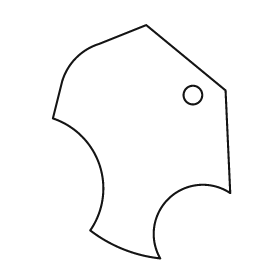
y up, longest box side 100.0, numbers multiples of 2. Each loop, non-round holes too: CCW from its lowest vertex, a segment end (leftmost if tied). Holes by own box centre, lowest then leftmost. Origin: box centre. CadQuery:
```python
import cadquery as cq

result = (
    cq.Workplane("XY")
    .moveTo(8.0, -50.0)
    .threePointArc((12.0, -24.0), (38.0, -22.0))
    .lineTo(36.0, 22.0)
    .lineTo(2.0, 50.0)
    .lineTo(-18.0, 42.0)
    .threePointArc((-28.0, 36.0), (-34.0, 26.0))
    .lineTo(-38.0, 10.0)
    .threePointArc((-18.0, -10.0), (-22.0, -38.0))
    .threePointArc((-8.0, -46.0), (8.0, -50.0))
    .close()
    .moveTo(22.0, 20.0)
    .circle(4.0)
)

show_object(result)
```